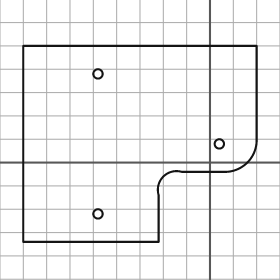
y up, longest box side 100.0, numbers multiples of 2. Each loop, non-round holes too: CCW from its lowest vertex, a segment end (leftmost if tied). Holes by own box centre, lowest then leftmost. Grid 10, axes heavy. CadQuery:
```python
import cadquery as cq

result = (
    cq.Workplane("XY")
    .moveTo(-80.0, -34.0)
    .lineTo(-22.0, -34.0)
    .lineTo(-22.0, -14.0)
    .threePointArc((-20.0, -6.0), (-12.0, -4.0))
    .lineTo(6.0, -4.0)
    .threePointArc((16.0, 0.0), (20.0, 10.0))
    .lineTo(20.0, 50.0)
    .lineTo(-80.0, 50.0)
    .close()
    .moveTo(-48.0, -22.0)
    .circle(2.0)
    .moveTo(4.0, 8.0)
    .circle(2.0)
    .moveTo(-48.0, 38.0)
    .circle(2.0)
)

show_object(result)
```